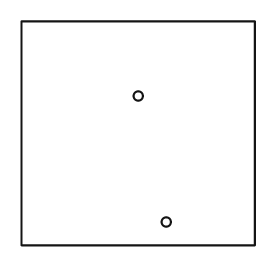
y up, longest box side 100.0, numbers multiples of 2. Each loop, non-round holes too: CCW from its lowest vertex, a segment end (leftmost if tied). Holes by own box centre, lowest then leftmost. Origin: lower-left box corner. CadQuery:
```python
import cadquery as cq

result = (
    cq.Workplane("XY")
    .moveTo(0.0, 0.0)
    .lineTo(100.0, 0.0)
    .lineTo(100.0, 96.0)
    .lineTo(0.0, 96.0)
    .close()
    .moveTo(62.0, 10.0)
    .circle(2.0)
    .moveTo(50.0, 64.0)
    .circle(2.0)
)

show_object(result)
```